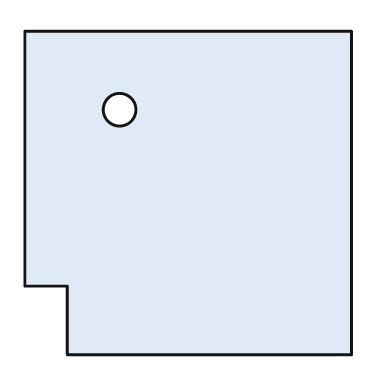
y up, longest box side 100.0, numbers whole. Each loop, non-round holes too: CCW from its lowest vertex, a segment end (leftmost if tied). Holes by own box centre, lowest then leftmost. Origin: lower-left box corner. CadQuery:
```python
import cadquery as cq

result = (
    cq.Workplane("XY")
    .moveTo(13.0, 0.0)
    .lineTo(100.0, 0.0)
    .lineTo(100.0, 99.0)
    .lineTo(0.0, 99.0)
    .lineTo(0.0, 21.0)
    .lineTo(13.0, 21.0)
    .close()
    .moveTo(29.0, 75.0)
    .circle(5.0)
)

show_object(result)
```